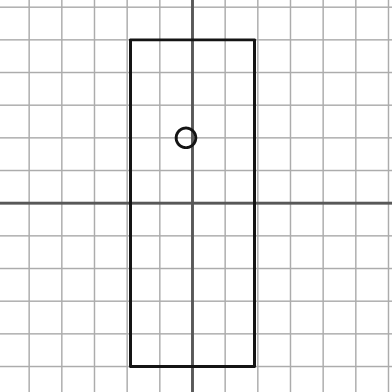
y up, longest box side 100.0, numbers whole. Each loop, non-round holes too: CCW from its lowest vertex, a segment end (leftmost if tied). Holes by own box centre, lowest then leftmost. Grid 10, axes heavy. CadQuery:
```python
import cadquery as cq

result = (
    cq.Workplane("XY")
    .moveTo(-19.0, -50.0)
    .lineTo(19.0, -50.0)
    .lineTo(19.0, 50.0)
    .lineTo(-19.0, 50.0)
    .close()
    .moveTo(-2.0, 20.0)
    .circle(3.0)
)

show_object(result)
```